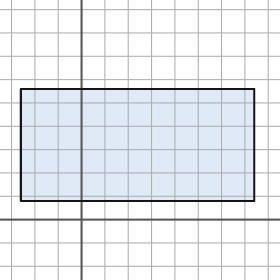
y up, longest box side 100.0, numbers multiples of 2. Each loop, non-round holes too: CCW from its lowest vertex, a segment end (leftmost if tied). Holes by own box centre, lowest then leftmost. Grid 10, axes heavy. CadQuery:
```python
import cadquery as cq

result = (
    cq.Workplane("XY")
    .moveTo(-26.0, 8.0)
    .lineTo(74.0, 8.0)
    .lineTo(74.0, 56.0)
    .lineTo(-26.0, 56.0)
    .close()
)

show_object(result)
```